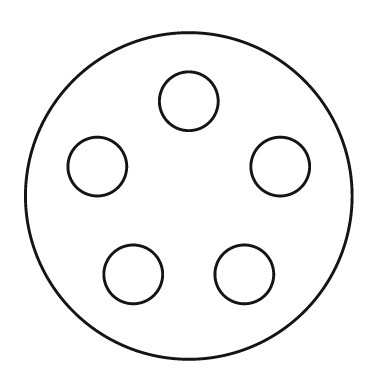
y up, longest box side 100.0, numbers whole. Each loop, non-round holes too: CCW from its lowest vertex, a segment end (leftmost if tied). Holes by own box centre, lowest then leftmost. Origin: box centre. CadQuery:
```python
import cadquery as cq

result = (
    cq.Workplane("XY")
    .moveTo(0.0, 0.0)
    .circle(50.0)
    .moveTo(-17.0, -24.0)
    .circle(9.0)
    .moveTo(17.0, -24.0)
    .circle(9.0)
    .moveTo(-28.0, 9.0)
    .circle(9.0)
    .moveTo(28.0, 9.0)
    .circle(9.0)
    .moveTo(0.0, 29.0)
    .circle(9.0)
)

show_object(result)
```